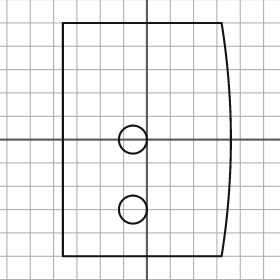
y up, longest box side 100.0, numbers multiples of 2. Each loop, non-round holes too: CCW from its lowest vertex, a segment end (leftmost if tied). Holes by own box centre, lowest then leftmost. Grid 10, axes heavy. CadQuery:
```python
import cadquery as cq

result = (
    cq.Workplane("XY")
    .moveTo(-36.0, -50.0)
    .lineTo(32.0, -50.0)
    .threePointArc((36.0, 0.0), (32.0, 50.0))
    .lineTo(-36.0, 50.0)
    .close()
    .moveTo(-6.0, -30.0)
    .circle(6.0)
    .moveTo(-6.0, 0.0)
    .circle(6.0)
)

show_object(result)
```